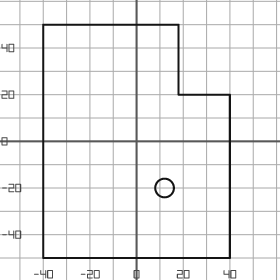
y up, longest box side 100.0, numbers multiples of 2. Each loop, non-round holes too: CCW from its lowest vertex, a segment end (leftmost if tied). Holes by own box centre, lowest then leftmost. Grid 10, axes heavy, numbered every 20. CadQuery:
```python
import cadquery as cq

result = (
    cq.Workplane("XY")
    .moveTo(-40.0, -50.0)
    .lineTo(40.0, -50.0)
    .lineTo(40.0, 20.0)
    .lineTo(18.0, 20.0)
    .lineTo(18.0, 50.0)
    .lineTo(-40.0, 50.0)
    .close()
    .moveTo(12.0, -20.0)
    .circle(4.0)
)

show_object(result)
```